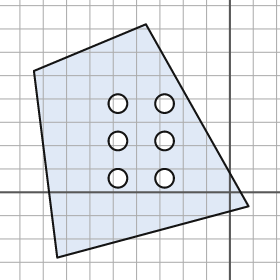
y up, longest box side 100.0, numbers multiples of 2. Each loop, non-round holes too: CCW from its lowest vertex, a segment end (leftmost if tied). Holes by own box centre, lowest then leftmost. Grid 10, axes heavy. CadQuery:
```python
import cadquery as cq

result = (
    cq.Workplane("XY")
    .moveTo(-74.0, -28.0)
    .lineTo(8.0, -6.0)
    .lineTo(-36.0, 72.0)
    .lineTo(-84.0, 52.0)
    .close()
    .moveTo(-48.0, 6.0)
    .circle(4.0)
    .moveTo(-28.0, 6.0)
    .circle(4.0)
    .moveTo(-48.0, 22.0)
    .circle(4.0)
    .moveTo(-28.0, 22.0)
    .circle(4.0)
    .moveTo(-48.0, 38.0)
    .circle(4.0)
    .moveTo(-28.0, 38.0)
    .circle(4.0)
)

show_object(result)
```